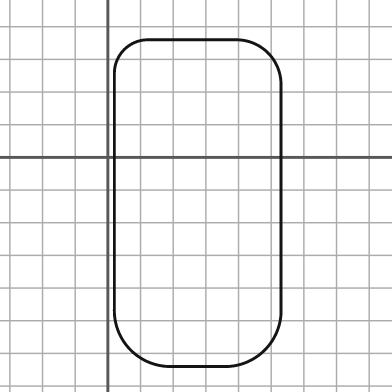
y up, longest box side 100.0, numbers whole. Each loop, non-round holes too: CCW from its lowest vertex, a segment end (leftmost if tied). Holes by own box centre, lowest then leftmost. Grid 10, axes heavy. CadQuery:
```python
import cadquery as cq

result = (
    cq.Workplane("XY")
    .moveTo(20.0, -64.0)
    .lineTo(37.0, -64.0)
    .threePointArc((48.0, -59.0), (53.0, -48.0))
    .lineTo(53.0, 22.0)
    .threePointArc((49.0, 32.0), (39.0, 36.0))
    .lineTo(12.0, 36.0)
    .threePointArc((5.0, 33.0), (2.0, 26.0))
    .lineTo(2.0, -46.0)
    .threePointArc((7.0, -59.0), (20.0, -64.0))
    .close()
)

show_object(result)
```